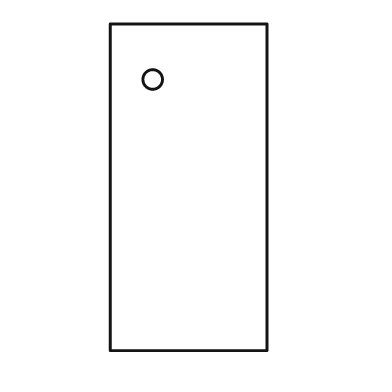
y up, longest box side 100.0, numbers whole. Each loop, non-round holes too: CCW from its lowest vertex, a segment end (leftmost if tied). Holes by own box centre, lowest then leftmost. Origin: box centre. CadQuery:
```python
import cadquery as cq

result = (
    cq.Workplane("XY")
    .moveTo(-24.0, -50.0)
    .lineTo(24.0, -50.0)
    .lineTo(24.0, 50.0)
    .lineTo(-24.0, 50.0)
    .close()
    .moveTo(-11.0, 33.0)
    .circle(3.0)
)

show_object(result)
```